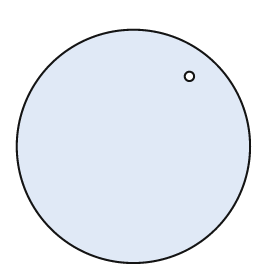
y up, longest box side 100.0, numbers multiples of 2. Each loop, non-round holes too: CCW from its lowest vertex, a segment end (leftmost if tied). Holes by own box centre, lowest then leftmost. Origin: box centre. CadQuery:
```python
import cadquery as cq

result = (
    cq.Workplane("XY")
    .moveTo(0.0, 0.0)
    .circle(50.0)
    .moveTo(24.0, 30.0)
    .circle(2.0)
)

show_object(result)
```